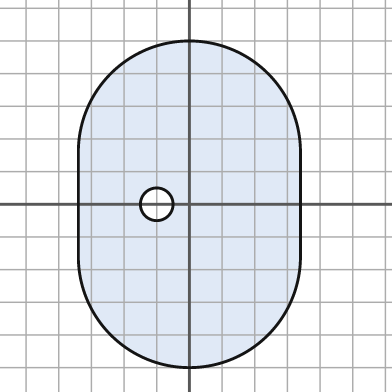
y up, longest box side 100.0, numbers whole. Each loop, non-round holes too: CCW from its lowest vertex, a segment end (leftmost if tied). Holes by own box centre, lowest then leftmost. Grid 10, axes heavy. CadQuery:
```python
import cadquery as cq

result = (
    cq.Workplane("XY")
    .moveTo(-34.0, -16.0)
    .threePointArc((0.0, -50.0), (34.0, -16.0))
    .lineTo(34.0, 16.0)
    .threePointArc((0.0, 50.0), (-34.0, 16.0))
    .close()
    .moveTo(-10.0, 0.0)
    .circle(5.0)
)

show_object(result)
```